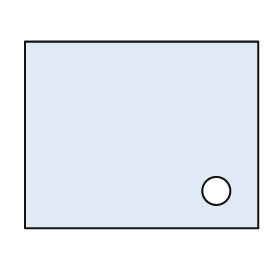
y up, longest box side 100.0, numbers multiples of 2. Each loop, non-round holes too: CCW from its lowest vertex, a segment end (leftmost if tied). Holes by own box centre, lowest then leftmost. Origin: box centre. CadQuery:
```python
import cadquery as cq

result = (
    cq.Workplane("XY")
    .moveTo(-50.0, -40.0)
    .lineTo(50.0, -40.0)
    .lineTo(50.0, 40.0)
    .lineTo(-50.0, 40.0)
    .close()
    .moveTo(32.0, -24.0)
    .circle(6.0)
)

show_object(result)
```